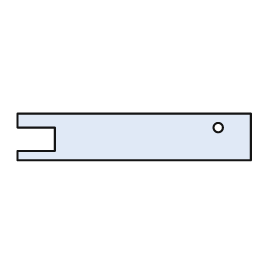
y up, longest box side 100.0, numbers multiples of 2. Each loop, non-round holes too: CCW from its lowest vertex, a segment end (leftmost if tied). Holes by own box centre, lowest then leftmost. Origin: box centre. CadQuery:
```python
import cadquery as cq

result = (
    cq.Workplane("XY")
    .moveTo(-50.0, -10.0)
    .lineTo(50.0, -10.0)
    .lineTo(50.0, 10.0)
    .lineTo(-50.0, 10.0)
    .lineTo(-50.0, 4.0)
    .lineTo(-34.0, 4.0)
    .lineTo(-34.0, -6.0)
    .lineTo(-50.0, -6.0)
    .close()
    .moveTo(36.0, 4.0)
    .circle(2.0)
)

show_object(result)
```